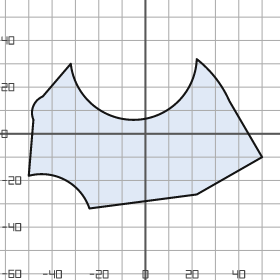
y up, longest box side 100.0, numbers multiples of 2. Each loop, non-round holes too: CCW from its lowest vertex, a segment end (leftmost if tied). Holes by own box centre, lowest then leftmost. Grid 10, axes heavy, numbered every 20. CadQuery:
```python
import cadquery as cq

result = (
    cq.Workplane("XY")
    .moveTo(-24.0, -32.0)
    .lineTo(22.0, -26.0)
    .lineTo(50.0, -10.0)
    .lineTo(36.0, 14.0)
    .threePointArc((30.0, 24.0), (22.0, 32.0))
    .threePointArc((-4.0, 6.0), (-32.0, 30.0))
    .lineTo(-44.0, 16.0)
    .threePointArc((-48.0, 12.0), (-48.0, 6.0))
    .lineTo(-50.0, -18.0)
    .threePointArc((-34.0, -20.0), (-24.0, -32.0))
    .close()
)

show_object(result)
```